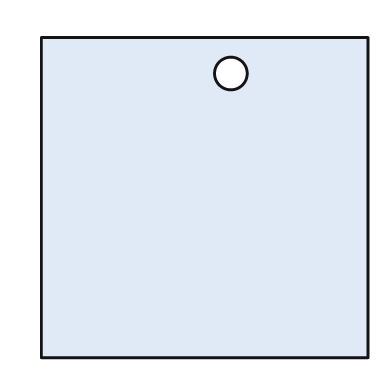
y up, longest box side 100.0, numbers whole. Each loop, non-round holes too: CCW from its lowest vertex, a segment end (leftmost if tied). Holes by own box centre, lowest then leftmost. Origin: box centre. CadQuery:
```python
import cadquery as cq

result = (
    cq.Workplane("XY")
    .moveTo(-50.0, -49.0)
    .lineTo(50.0, -49.0)
    .lineTo(50.0, 49.0)
    .lineTo(-50.0, 49.0)
    .close()
    .moveTo(8.0, 38.0)
    .circle(5.0)
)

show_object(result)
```